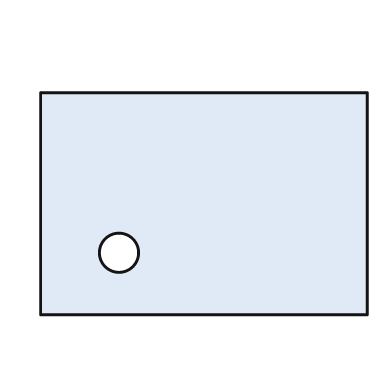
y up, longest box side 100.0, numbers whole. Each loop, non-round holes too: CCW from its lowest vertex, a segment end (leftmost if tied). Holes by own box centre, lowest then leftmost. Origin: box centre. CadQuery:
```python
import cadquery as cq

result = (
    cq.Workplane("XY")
    .moveTo(-50.0, -34.0)
    .lineTo(50.0, -34.0)
    .lineTo(50.0, 34.0)
    .lineTo(-50.0, 34.0)
    .close()
    .moveTo(-26.0, -15.0)
    .circle(6.0)
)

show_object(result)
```